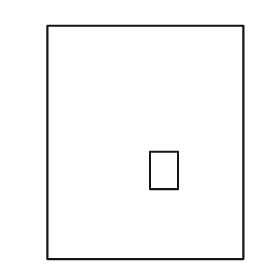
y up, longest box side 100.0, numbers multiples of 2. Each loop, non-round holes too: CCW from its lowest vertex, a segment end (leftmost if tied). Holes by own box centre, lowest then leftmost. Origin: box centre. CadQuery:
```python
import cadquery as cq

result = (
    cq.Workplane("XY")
    .moveTo(-42.0, -50.0)
    .lineTo(42.0, -50.0)
    .lineTo(42.0, 50.0)
    .lineTo(-42.0, 50.0)
    .close()
    .moveTo(2.0, -20.0)
    .lineTo(14.0, -20.0)
    .lineTo(14.0, -4.0)
    .lineTo(2.0, -4.0)
    .close()
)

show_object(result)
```